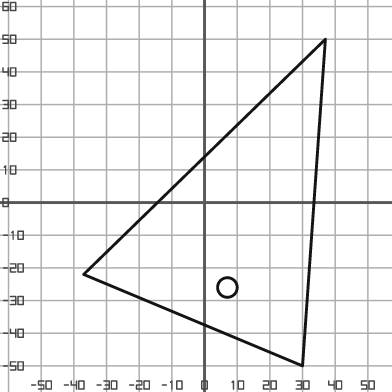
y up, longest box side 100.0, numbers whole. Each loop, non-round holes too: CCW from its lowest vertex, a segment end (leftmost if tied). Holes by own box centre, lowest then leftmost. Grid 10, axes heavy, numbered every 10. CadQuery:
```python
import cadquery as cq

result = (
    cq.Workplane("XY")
    .moveTo(30.0, -50.0)
    .lineTo(37.0, 50.0)
    .lineTo(-37.0, -22.0)
    .close()
    .moveTo(7.0, -26.0)
    .circle(3.0)
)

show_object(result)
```